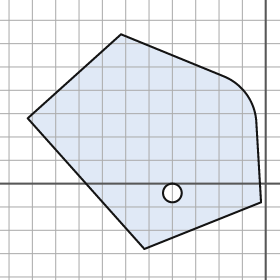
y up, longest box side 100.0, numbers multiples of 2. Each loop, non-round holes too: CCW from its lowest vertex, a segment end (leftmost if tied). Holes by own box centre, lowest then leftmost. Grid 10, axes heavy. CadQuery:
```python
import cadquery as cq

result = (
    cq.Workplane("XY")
    .moveTo(-52.0, -28.0)
    .lineTo(-2.0, -8.0)
    .lineTo(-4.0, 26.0)
    .threePointArc((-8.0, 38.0), (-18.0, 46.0))
    .lineTo(-62.0, 64.0)
    .lineTo(-102.0, 28.0)
    .close()
    .moveTo(-40.0, -4.0)
    .circle(4.0)
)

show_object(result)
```